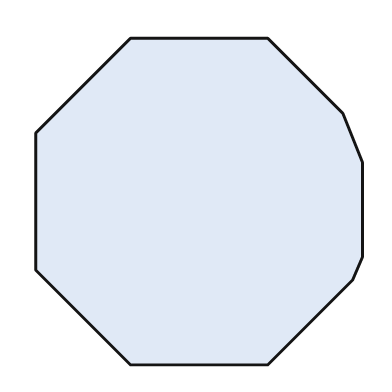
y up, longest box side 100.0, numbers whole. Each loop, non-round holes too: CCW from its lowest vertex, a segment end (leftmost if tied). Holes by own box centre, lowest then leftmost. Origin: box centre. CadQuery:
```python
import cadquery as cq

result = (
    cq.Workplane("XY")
    .moveTo(-21.0, -50.0)
    .lineTo(21.0, -50.0)
    .lineTo(47.0, -24.0)
    .lineTo(50.0, -17.0)
    .lineTo(50.0, 12.0)
    .lineTo(44.0, 27.0)
    .lineTo(21.0, 50.0)
    .lineTo(-21.0, 50.0)
    .lineTo(-50.0, 21.0)
    .lineTo(-50.0, -21.0)
    .close()
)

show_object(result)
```